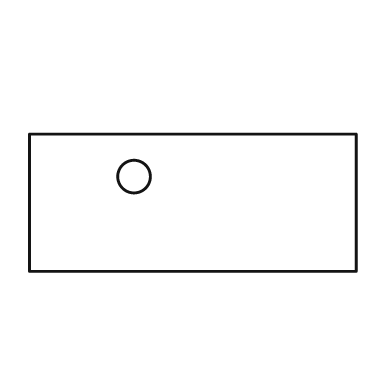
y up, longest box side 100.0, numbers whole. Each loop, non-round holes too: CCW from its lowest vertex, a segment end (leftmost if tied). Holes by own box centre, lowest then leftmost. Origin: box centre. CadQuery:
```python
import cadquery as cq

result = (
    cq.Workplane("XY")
    .moveTo(-50.0, -21.0)
    .lineTo(50.0, -21.0)
    .lineTo(50.0, 21.0)
    .lineTo(-50.0, 21.0)
    .close()
    .moveTo(-18.0, 8.0)
    .circle(5.0)
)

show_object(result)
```